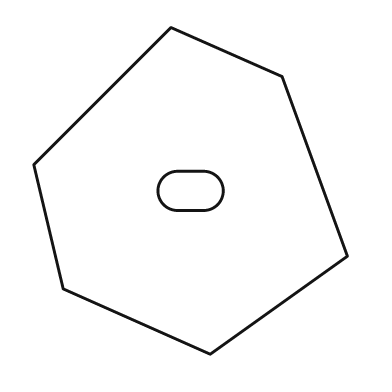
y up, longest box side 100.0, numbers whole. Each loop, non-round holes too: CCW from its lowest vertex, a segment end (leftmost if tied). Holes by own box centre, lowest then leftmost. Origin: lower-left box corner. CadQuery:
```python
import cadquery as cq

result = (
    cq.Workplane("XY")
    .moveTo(54.0, 0.0)
    .lineTo(96.0, 30.0)
    .lineTo(76.0, 85.0)
    .lineTo(42.0, 100.0)
    .lineTo(0.0, 58.0)
    .lineTo(9.0, 20.0)
    .close()
    .moveTo(44.0, 44.0)
    .lineTo(52.0, 44.0)
    .threePointArc((58.0, 50.0), (52.0, 56.0))
    .lineTo(44.0, 56.0)
    .threePointArc((38.0, 50.0), (44.0, 44.0))
    .close()
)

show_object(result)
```